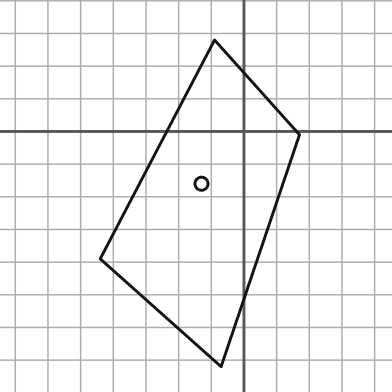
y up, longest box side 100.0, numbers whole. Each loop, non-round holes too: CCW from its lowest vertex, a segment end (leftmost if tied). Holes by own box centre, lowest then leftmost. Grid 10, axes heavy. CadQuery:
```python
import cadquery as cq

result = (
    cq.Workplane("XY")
    .moveTo(-7.0, -72.0)
    .lineTo(17.0, -1.0)
    .lineTo(-9.0, 28.0)
    .lineTo(-44.0, -39.0)
    .close()
    .moveTo(-13.0, -16.0)
    .circle(2.0)
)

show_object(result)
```